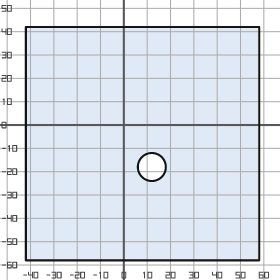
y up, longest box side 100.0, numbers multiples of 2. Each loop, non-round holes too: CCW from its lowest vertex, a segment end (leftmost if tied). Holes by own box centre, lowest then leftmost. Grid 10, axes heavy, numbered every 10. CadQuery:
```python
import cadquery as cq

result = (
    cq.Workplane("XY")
    .moveTo(-42.0, -58.0)
    .lineTo(58.0, -58.0)
    .lineTo(58.0, 42.0)
    .lineTo(-42.0, 42.0)
    .close()
    .moveTo(12.0, -18.0)
    .circle(6.0)
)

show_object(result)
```